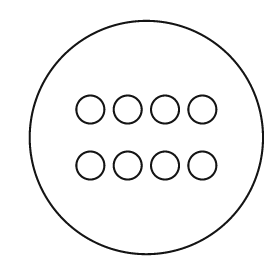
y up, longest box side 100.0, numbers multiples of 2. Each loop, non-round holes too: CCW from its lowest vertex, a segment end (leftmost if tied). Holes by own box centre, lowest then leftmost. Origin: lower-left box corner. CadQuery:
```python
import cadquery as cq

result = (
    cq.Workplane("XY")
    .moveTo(50.0, 50.0)
    .circle(50.0)
    .moveTo(26.0, 38.0)
    .circle(6.0)
    .moveTo(42.0, 38.0)
    .circle(6.0)
    .moveTo(58.0, 38.0)
    .circle(6.0)
    .moveTo(74.0, 38.0)
    .circle(6.0)
    .moveTo(26.0, 62.0)
    .circle(6.0)
    .moveTo(42.0, 62.0)
    .circle(6.0)
    .moveTo(58.0, 62.0)
    .circle(6.0)
    .moveTo(74.0, 62.0)
    .circle(6.0)
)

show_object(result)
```